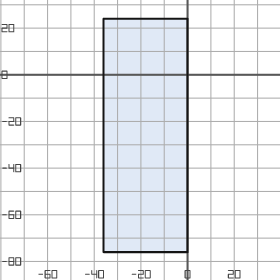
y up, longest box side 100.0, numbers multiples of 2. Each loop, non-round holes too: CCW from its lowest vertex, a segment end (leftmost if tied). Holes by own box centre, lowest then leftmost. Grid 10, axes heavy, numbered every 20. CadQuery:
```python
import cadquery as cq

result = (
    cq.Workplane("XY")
    .moveTo(-36.0, -76.0)
    .lineTo(0.0, -76.0)
    .lineTo(0.0, 24.0)
    .lineTo(-36.0, 24.0)
    .close()
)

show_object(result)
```